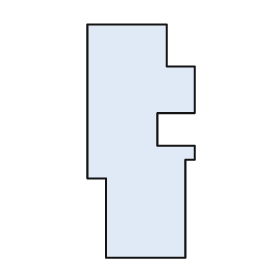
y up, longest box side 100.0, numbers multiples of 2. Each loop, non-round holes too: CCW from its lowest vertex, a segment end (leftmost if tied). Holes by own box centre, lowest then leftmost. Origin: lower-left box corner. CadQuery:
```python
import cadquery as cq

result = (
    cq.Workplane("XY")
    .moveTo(8.0, 0.0)
    .lineTo(42.0, 0.0)
    .lineTo(42.0, 42.0)
    .lineTo(46.0, 42.0)
    .lineTo(46.0, 48.0)
    .lineTo(30.0, 48.0)
    .lineTo(30.0, 62.0)
    .lineTo(46.0, 62.0)
    .lineTo(46.0, 82.0)
    .lineTo(34.0, 82.0)
    .lineTo(34.0, 100.0)
    .lineTo(0.0, 100.0)
    .lineTo(0.0, 34.0)
    .lineTo(8.0, 34.0)
    .close()
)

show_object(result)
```